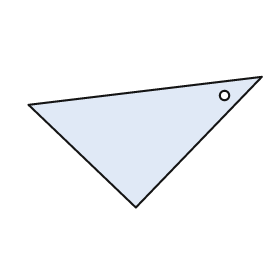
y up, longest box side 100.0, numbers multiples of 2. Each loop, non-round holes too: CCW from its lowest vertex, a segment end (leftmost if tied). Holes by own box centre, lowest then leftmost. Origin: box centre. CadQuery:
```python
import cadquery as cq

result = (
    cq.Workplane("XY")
    .moveTo(-4.0, -28.0)
    .lineTo(50.0, 28.0)
    .lineTo(-50.0, 16.0)
    .close()
    .moveTo(34.0, 20.0)
    .circle(2.0)
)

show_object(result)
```